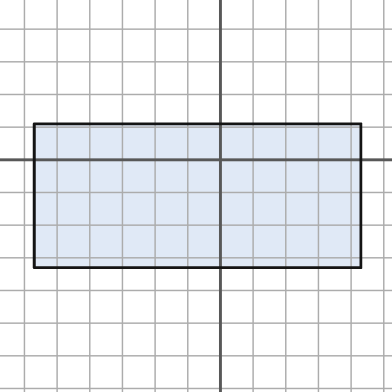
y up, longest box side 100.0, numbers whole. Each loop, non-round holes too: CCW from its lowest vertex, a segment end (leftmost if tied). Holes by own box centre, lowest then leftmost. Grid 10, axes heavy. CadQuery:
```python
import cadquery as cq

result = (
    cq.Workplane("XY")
    .moveTo(-57.0, -33.0)
    .lineTo(43.0, -33.0)
    .lineTo(43.0, 11.0)
    .lineTo(-57.0, 11.0)
    .close()
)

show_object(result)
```